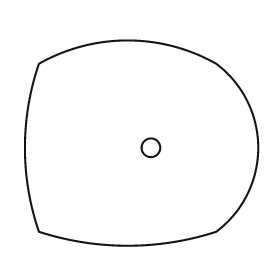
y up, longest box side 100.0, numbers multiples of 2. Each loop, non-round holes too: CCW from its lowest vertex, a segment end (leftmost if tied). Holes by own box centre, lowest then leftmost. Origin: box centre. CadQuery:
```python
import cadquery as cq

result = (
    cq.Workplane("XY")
    .moveTo(-44.0, -38.0)
    .threePointArc((-6.0, -44.0), (32.0, -38.0))
    .threePointArc((50.0, -2.0), (32.0, 34.0))
    .threePointArc((-6.0, 44.0), (-44.0, 34.0))
    .threePointArc((-50.0, -2.0), (-44.0, -38.0))
    .close()
    .moveTo(4.0, -2.0)
    .circle(4.0)
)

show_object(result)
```